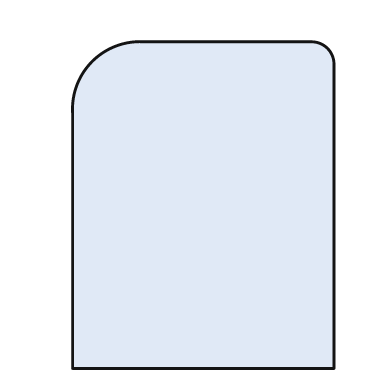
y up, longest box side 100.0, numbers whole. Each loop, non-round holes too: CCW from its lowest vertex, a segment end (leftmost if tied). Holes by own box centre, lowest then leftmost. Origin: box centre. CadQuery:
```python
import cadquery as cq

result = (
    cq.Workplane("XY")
    .moveTo(-40.0, -50.0)
    .lineTo(40.0, -50.0)
    .lineTo(40.0, 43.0)
    .threePointArc((38.0, 48.0), (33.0, 50.0))
    .lineTo(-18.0, 50.0)
    .threePointArc((-34.0, 44.0), (-40.0, 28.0))
    .close()
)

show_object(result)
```